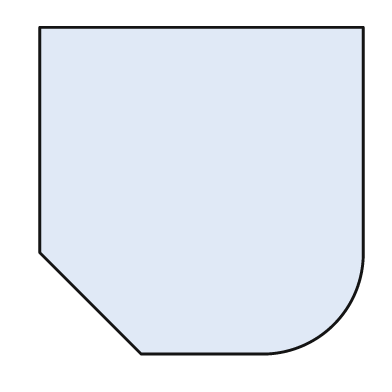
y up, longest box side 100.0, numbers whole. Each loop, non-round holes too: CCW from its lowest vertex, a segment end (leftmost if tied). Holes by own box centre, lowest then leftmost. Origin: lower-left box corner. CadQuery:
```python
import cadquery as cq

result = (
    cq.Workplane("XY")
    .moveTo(31.0, 0.0)
    .lineTo(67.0, 0.0)
    .threePointArc((90.0, 9.0), (99.0, 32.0))
    .lineTo(99.0, 100.0)
    .lineTo(0.0, 100.0)
    .lineTo(0.0, 31.0)
    .close()
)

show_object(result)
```